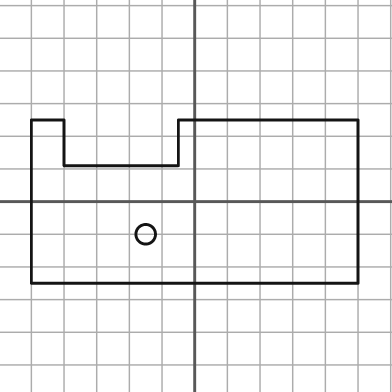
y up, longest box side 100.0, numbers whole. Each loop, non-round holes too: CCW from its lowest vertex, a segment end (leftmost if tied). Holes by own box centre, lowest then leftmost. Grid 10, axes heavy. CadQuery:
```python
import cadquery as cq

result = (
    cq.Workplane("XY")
    .moveTo(-50.0, -25.0)
    .lineTo(50.0, -25.0)
    .lineTo(50.0, 25.0)
    .lineTo(-5.0, 25.0)
    .lineTo(-5.0, 11.0)
    .lineTo(-40.0, 11.0)
    .lineTo(-40.0, 25.0)
    .lineTo(-50.0, 25.0)
    .close()
    .moveTo(-15.0, -10.0)
    .circle(3.0)
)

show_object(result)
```